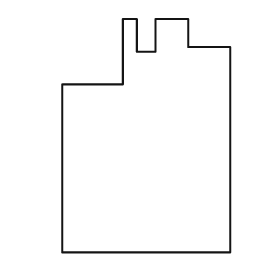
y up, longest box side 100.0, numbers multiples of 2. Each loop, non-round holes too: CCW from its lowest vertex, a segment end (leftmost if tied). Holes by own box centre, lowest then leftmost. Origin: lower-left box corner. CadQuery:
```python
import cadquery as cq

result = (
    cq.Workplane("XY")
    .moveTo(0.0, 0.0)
    .lineTo(72.0, 0.0)
    .lineTo(72.0, 88.0)
    .lineTo(54.0, 88.0)
    .lineTo(54.0, 100.0)
    .lineTo(40.0, 100.0)
    .lineTo(40.0, 86.0)
    .lineTo(32.0, 86.0)
    .lineTo(32.0, 100.0)
    .lineTo(26.0, 100.0)
    .lineTo(26.0, 72.0)
    .lineTo(0.0, 72.0)
    .close()
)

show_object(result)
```